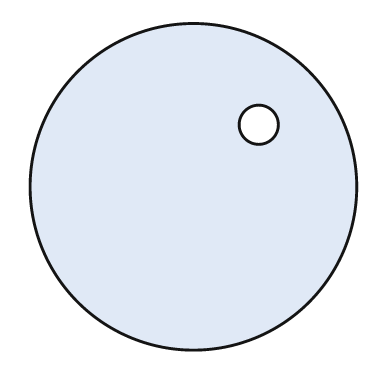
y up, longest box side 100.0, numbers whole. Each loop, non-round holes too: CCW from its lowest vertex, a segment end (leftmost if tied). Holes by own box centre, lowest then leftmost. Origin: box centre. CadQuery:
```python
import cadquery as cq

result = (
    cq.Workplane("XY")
    .moveTo(0.0, 0.0)
    .circle(50.0)
    .moveTo(20.0, 19.0)
    .circle(6.0)
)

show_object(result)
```